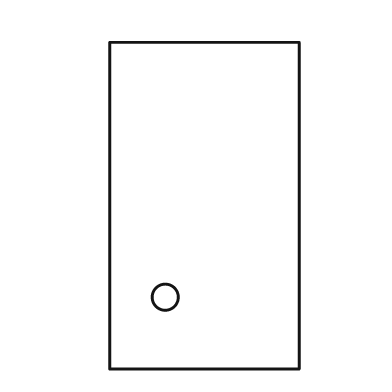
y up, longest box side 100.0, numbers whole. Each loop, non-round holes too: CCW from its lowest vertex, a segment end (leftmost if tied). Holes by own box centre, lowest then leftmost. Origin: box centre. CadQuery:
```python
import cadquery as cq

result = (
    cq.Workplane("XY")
    .moveTo(-29.0, -50.0)
    .lineTo(29.0, -50.0)
    .lineTo(29.0, 50.0)
    .lineTo(-29.0, 50.0)
    .close()
    .moveTo(-12.0, -28.0)
    .circle(4.0)
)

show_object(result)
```